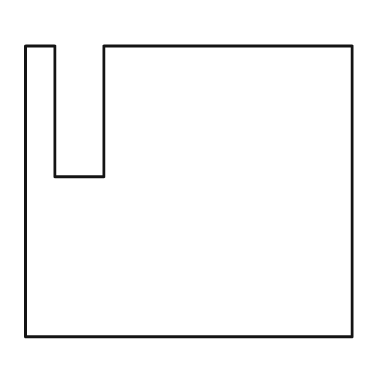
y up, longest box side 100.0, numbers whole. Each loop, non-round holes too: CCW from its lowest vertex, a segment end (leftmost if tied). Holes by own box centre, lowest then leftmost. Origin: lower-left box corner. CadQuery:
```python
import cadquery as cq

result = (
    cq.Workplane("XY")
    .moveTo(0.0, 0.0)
    .lineTo(100.0, 0.0)
    .lineTo(100.0, 89.0)
    .lineTo(24.0, 89.0)
    .lineTo(24.0, 49.0)
    .lineTo(9.0, 49.0)
    .lineTo(9.0, 89.0)
    .lineTo(0.0, 89.0)
    .close()
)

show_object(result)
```